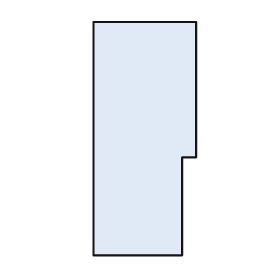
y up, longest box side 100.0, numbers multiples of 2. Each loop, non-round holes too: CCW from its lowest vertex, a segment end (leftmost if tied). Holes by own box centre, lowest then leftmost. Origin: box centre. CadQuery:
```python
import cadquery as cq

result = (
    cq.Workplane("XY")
    .moveTo(-22.0, -50.0)
    .lineTo(16.0, -50.0)
    .lineTo(16.0, -8.0)
    .lineTo(22.0, -8.0)
    .lineTo(22.0, 50.0)
    .lineTo(-22.0, 50.0)
    .close()
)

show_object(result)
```